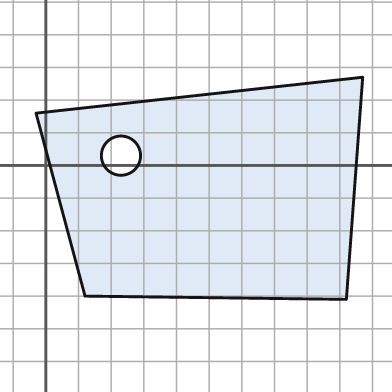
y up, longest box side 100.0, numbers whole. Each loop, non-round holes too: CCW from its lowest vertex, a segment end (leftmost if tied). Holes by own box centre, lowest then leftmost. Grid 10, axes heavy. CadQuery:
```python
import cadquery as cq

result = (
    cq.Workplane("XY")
    .moveTo(92.0, -41.0)
    .lineTo(97.0, 27.0)
    .lineTo(-3.0, 16.0)
    .lineTo(12.0, -40.0)
    .close()
    .moveTo(23.0, 3.0)
    .circle(6.0)
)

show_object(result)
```